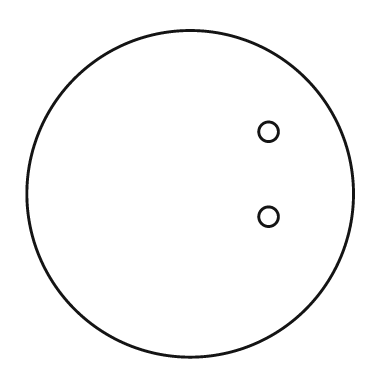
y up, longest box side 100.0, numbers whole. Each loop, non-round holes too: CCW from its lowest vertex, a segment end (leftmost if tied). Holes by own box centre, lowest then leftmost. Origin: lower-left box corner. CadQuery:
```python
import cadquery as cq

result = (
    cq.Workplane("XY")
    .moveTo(50.0, 50.0)
    .circle(50.0)
    .moveTo(74.0, 43.0)
    .circle(3.0)
    .moveTo(74.0, 69.0)
    .circle(3.0)
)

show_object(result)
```